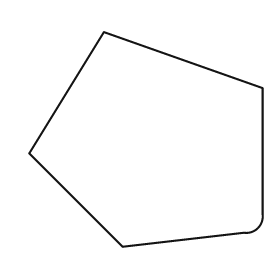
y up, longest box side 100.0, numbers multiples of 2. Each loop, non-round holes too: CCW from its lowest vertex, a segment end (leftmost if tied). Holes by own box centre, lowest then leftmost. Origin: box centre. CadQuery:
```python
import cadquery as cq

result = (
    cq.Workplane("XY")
    .moveTo(-10.0, -46.0)
    .lineTo(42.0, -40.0)
    .threePointArc((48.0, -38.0), (50.0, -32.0))
    .lineTo(50.0, 22.0)
    .lineTo(-18.0, 46.0)
    .lineTo(-50.0, -6.0)
    .close()
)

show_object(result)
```